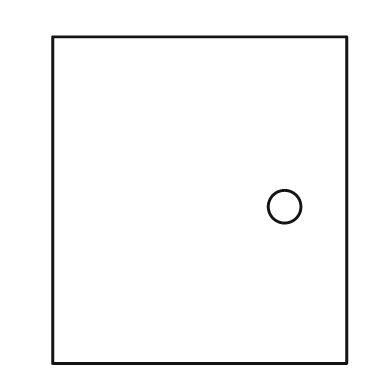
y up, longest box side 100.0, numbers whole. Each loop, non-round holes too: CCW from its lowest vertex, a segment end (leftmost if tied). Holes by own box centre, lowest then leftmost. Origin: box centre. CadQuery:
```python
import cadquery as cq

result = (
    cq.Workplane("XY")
    .moveTo(-45.0, -50.0)
    .lineTo(45.0, -50.0)
    .lineTo(45.0, 50.0)
    .lineTo(-45.0, 50.0)
    .close()
    .moveTo(26.0, -2.0)
    .circle(5.0)
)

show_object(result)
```